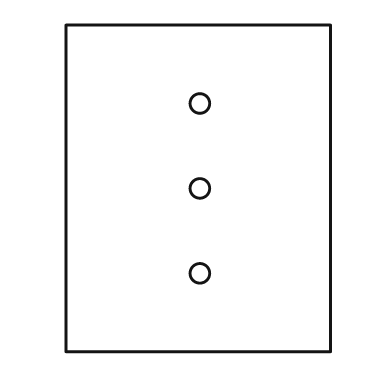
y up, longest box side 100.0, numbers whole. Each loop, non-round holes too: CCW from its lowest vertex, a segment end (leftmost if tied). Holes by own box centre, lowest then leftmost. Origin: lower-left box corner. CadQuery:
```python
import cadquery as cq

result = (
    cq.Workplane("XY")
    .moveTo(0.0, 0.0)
    .lineTo(81.0, 0.0)
    .lineTo(81.0, 100.0)
    .lineTo(0.0, 100.0)
    .close()
    .moveTo(41.0, 24.0)
    .circle(3.0)
    .moveTo(41.0, 50.0)
    .circle(3.0)
    .moveTo(41.0, 76.0)
    .circle(3.0)
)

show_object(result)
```